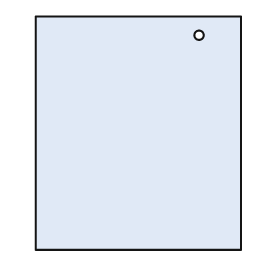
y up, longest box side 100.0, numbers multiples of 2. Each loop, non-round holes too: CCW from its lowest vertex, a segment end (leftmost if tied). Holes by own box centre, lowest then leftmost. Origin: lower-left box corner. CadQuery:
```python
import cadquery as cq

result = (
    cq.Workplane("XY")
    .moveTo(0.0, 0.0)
    .lineTo(88.0, 0.0)
    .lineTo(88.0, 100.0)
    .lineTo(0.0, 100.0)
    .close()
    .moveTo(70.0, 92.0)
    .circle(2.0)
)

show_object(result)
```